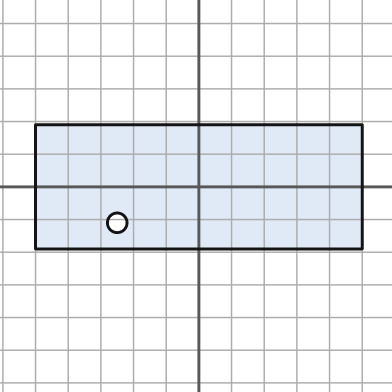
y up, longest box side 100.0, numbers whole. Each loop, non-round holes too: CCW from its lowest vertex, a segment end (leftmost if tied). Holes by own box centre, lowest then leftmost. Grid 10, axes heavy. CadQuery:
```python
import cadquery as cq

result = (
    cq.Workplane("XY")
    .moveTo(-50.0, -19.0)
    .lineTo(50.0, -19.0)
    .lineTo(50.0, 19.0)
    .lineTo(-50.0, 19.0)
    .close()
    .moveTo(-25.0, -11.0)
    .circle(3.0)
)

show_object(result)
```